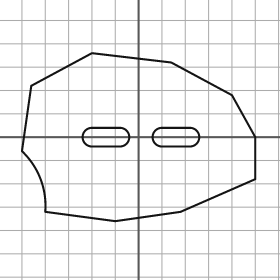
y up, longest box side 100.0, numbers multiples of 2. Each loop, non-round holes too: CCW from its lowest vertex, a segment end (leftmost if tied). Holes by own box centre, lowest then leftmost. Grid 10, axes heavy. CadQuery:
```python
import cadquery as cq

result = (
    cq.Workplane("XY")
    .moveTo(-10.0, -36.0)
    .lineTo(18.0, -32.0)
    .lineTo(50.0, -18.0)
    .lineTo(50.0, 0.0)
    .lineTo(40.0, 18.0)
    .lineTo(14.0, 32.0)
    .lineTo(-20.0, 36.0)
    .lineTo(-46.0, 22.0)
    .lineTo(-50.0, -6.0)
    .threePointArc((-42.0, -18.0), (-40.0, -32.0))
    .close()
    .moveTo(-20.0, -4.0)
    .lineTo(-8.0, -4.0)
    .threePointArc((-4.0, 0.0), (-8.0, 4.0))
    .lineTo(-20.0, 4.0)
    .threePointArc((-24.0, 0.0), (-20.0, -4.0))
    .close()
    .moveTo(10.0, -4.0)
    .lineTo(22.0, -4.0)
    .threePointArc((26.0, 0.0), (22.0, 4.0))
    .lineTo(10.0, 4.0)
    .threePointArc((6.0, 0.0), (10.0, -4.0))
    .close()
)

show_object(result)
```